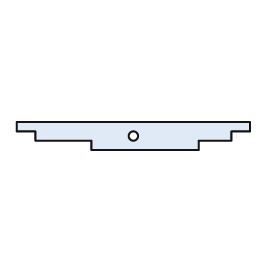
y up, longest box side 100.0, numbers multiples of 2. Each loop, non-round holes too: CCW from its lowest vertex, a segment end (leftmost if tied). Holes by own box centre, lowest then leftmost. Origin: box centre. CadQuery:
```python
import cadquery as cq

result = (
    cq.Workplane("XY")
    .moveTo(-18.0, -6.0)
    .lineTo(28.0, -6.0)
    .lineTo(28.0, -2.0)
    .lineTo(42.0, -2.0)
    .lineTo(42.0, 2.0)
    .lineTo(50.0, 2.0)
    .lineTo(50.0, 6.0)
    .lineTo(-50.0, 6.0)
    .lineTo(-50.0, 2.0)
    .lineTo(-42.0, 2.0)
    .lineTo(-42.0, -2.0)
    .lineTo(-18.0, -2.0)
    .close()
    .moveTo(0.0, 0.0)
    .circle(2.0)
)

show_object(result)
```